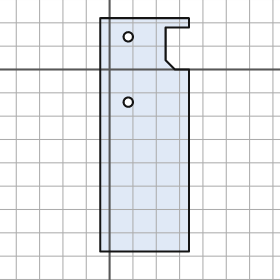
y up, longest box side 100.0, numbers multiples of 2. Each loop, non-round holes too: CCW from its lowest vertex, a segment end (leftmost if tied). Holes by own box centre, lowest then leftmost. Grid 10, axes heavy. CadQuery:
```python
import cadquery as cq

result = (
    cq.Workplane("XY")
    .moveTo(-4.0, -78.0)
    .lineTo(34.0, -78.0)
    .lineTo(34.0, 0.0)
    .lineTo(28.0, 0.0)
    .lineTo(24.0, 4.0)
    .lineTo(24.0, 18.0)
    .lineTo(34.0, 18.0)
    .lineTo(34.0, 22.0)
    .lineTo(-4.0, 22.0)
    .close()
    .moveTo(8.0, -14.0)
    .circle(2.0)
    .moveTo(8.0, 14.0)
    .circle(2.0)
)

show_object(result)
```